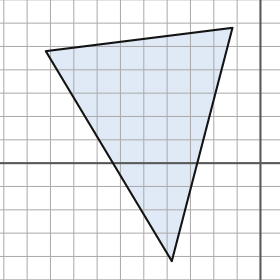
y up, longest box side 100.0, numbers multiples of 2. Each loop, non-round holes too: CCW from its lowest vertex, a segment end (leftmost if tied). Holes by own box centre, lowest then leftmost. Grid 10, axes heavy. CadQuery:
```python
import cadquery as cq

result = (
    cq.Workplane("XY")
    .moveTo(-38.0, -42.0)
    .lineTo(-12.0, 58.0)
    .lineTo(-92.0, 48.0)
    .close()
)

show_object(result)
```